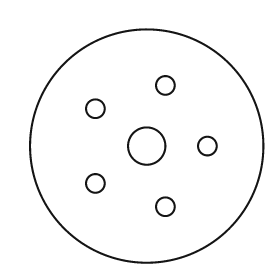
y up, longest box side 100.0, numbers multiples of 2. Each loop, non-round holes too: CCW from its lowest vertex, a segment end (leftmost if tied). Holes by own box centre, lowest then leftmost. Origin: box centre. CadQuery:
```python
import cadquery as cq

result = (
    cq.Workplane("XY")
    .moveTo(0.0, 0.0)
    .circle(50.0)
    .moveTo(8.0, -26.0)
    .circle(4.0)
    .moveTo(-22.0, -16.0)
    .circle(4.0)
    .moveTo(0.0, 0.0)
    .circle(8.0)
    .moveTo(26.0, 0.0)
    .circle(4.0)
    .moveTo(-22.0, 16.0)
    .circle(4.0)
    .moveTo(8.0, 26.0)
    .circle(4.0)
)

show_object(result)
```